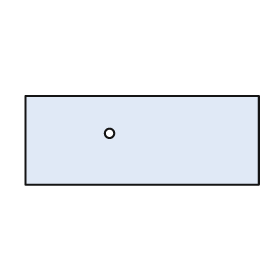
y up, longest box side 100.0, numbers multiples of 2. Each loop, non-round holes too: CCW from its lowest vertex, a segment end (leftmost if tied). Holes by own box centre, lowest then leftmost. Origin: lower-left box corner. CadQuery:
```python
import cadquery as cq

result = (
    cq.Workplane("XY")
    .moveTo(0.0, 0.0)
    .lineTo(100.0, 0.0)
    .lineTo(100.0, 38.0)
    .lineTo(0.0, 38.0)
    .close()
    .moveTo(36.0, 22.0)
    .circle(2.0)
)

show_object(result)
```